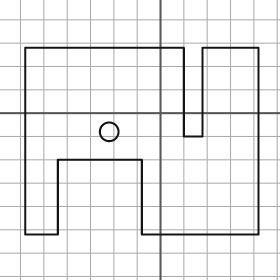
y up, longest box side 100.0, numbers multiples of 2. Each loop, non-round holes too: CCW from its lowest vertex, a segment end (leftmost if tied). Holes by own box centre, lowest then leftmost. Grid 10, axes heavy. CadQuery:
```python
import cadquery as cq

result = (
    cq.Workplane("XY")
    .moveTo(-58.0, -52.0)
    .lineTo(-44.0, -52.0)
    .lineTo(-44.0, -20.0)
    .lineTo(-8.0, -20.0)
    .lineTo(-8.0, -52.0)
    .lineTo(42.0, -52.0)
    .lineTo(42.0, 28.0)
    .lineTo(18.0, 28.0)
    .lineTo(18.0, -10.0)
    .lineTo(10.0, -10.0)
    .lineTo(10.0, 28.0)
    .lineTo(-58.0, 28.0)
    .close()
    .moveTo(-22.0, -8.0)
    .circle(4.0)
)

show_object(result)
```